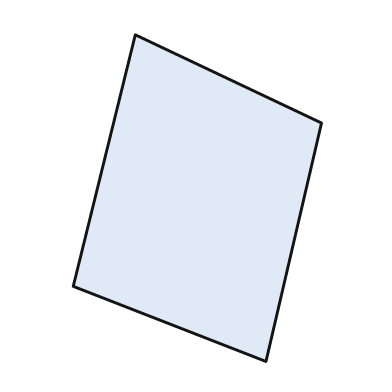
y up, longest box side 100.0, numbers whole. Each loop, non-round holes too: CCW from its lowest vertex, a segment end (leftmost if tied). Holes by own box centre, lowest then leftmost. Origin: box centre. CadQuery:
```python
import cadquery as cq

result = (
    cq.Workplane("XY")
    .moveTo(21.0, -50.0)
    .lineTo(38.0, 23.0)
    .lineTo(-19.0, 50.0)
    .lineTo(-38.0, -27.0)
    .close()
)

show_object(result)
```